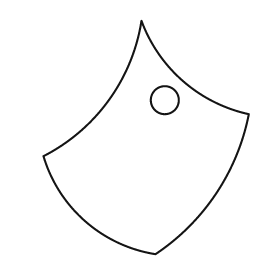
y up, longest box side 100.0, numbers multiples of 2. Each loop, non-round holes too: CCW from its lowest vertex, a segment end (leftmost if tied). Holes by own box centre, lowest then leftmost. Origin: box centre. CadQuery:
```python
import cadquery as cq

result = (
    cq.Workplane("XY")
    .moveTo(4.0, -50.0)
    .threePointArc((30.0, -24.0), (44.0, 10.0))
    .threePointArc((16.0, 24.0), (-2.0, 50.0))
    .threePointArc((-16.0, 16.0), (-44.0, -8.0))
    .threePointArc((-26.0, -36.0), (4.0, -50.0))
    .close()
    .moveTo(8.0, 16.0)
    .circle(6.0)
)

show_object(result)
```